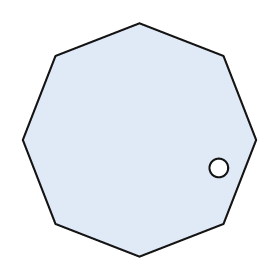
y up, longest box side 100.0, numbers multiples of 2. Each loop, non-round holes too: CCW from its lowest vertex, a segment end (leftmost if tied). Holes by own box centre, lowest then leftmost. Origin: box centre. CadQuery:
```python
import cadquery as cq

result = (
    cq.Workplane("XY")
    .moveTo(0.0, -50.0)
    .lineTo(36.0, -36.0)
    .lineTo(50.0, 0.0)
    .lineTo(36.0, 36.0)
    .lineTo(0.0, 50.0)
    .lineTo(-36.0, 36.0)
    .lineTo(-50.0, 0.0)
    .lineTo(-36.0, -36.0)
    .close()
    .moveTo(34.0, -12.0)
    .circle(4.0)
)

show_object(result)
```